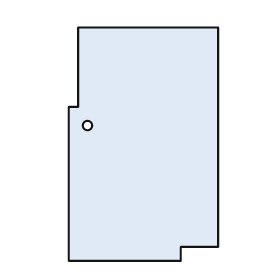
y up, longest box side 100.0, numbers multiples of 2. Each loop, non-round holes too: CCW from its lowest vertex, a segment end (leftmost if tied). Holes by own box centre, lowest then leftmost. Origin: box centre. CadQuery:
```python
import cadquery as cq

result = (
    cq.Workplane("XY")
    .moveTo(-32.0, -50.0)
    .lineTo(16.0, -50.0)
    .lineTo(16.0, -44.0)
    .lineTo(32.0, -44.0)
    .lineTo(32.0, 50.0)
    .lineTo(-28.0, 50.0)
    .lineTo(-28.0, 16.0)
    .lineTo(-32.0, 16.0)
    .close()
    .moveTo(-24.0, 8.0)
    .circle(2.0)
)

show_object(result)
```